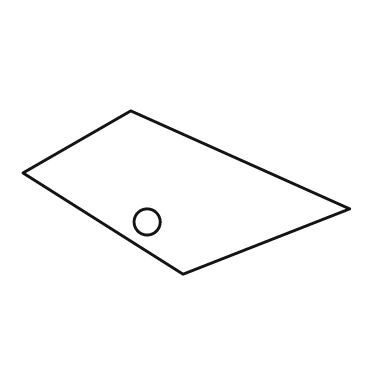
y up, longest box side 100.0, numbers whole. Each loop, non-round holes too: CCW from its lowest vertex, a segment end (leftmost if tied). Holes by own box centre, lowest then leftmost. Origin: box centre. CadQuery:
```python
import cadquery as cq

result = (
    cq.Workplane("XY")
    .moveTo(-1.0, -25.0)
    .lineTo(50.0, -5.0)
    .lineTo(-17.0, 25.0)
    .lineTo(-50.0, 6.0)
    .close()
    .moveTo(-12.0, -9.0)
    .circle(4.0)
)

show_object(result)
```